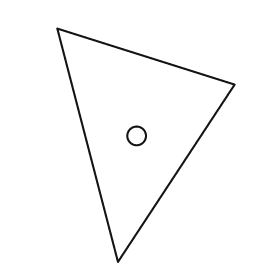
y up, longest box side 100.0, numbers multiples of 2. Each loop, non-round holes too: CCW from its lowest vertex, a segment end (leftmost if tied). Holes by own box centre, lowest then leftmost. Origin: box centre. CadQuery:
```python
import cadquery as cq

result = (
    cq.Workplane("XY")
    .moveTo(-12.0, -50.0)
    .lineTo(38.0, 26.0)
    .lineTo(-38.0, 50.0)
    .close()
    .moveTo(-4.0, 4.0)
    .circle(4.0)
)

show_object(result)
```